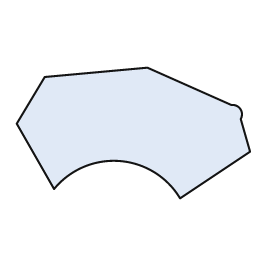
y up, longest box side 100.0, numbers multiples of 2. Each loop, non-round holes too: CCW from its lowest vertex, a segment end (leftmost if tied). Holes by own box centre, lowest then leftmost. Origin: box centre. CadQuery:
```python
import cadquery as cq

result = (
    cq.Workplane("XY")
    .moveTo(20.0, -28.0)
    .lineTo(50.0, -8.0)
    .lineTo(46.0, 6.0)
    .threePointArc((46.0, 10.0), (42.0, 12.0))
    .lineTo(6.0, 28.0)
    .lineTo(-38.0, 24.0)
    .lineTo(-50.0, 4.0)
    .lineTo(-34.0, -24.0)
    .threePointArc((-6.0, -12.0), (20.0, -28.0))
    .close()
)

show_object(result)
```